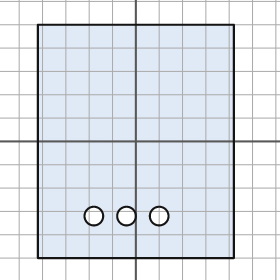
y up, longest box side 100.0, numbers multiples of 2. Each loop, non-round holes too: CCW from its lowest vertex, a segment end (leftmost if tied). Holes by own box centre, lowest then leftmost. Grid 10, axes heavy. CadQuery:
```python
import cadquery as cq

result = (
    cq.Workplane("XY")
    .moveTo(-42.0, -50.0)
    .lineTo(42.0, -50.0)
    .lineTo(42.0, 50.0)
    .lineTo(-42.0, 50.0)
    .close()
    .moveTo(-18.0, -32.0)
    .circle(4.0)
    .moveTo(-4.0, -32.0)
    .circle(4.0)
    .moveTo(10.0, -32.0)
    .circle(4.0)
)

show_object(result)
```